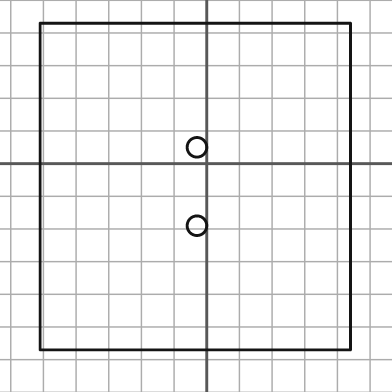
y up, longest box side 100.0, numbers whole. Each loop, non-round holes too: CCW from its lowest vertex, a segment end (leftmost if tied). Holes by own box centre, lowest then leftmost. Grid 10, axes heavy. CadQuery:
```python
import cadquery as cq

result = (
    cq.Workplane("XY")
    .moveTo(-51.0, -57.0)
    .lineTo(44.0, -57.0)
    .lineTo(44.0, 43.0)
    .lineTo(-51.0, 43.0)
    .close()
    .moveTo(-3.0, -19.0)
    .circle(3.0)
    .moveTo(-3.0, 5.0)
    .circle(3.0)
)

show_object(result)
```